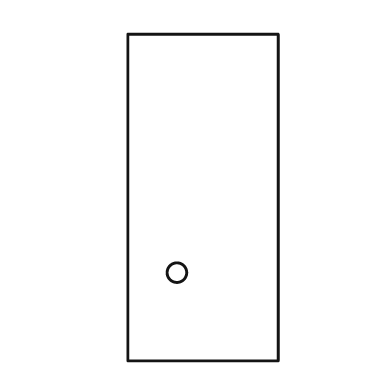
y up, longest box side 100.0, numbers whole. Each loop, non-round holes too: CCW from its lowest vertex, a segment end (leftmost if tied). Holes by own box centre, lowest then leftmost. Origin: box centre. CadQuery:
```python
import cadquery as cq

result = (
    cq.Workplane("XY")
    .moveTo(-23.0, -50.0)
    .lineTo(23.0, -50.0)
    .lineTo(23.0, 50.0)
    .lineTo(-23.0, 50.0)
    .close()
    .moveTo(-8.0, -23.0)
    .circle(3.0)
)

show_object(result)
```